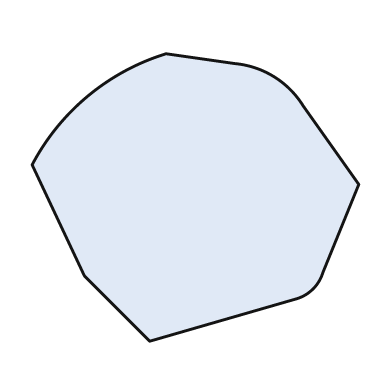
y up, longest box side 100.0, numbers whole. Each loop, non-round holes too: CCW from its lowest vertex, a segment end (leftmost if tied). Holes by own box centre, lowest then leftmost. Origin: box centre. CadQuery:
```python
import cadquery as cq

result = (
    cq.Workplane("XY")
    .moveTo(-14.0, -44.0)
    .lineTo(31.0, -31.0)
    .threePointArc((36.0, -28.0), (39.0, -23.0))
    .lineTo(50.0, 4.0)
    .lineTo(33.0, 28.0)
    .threePointArc((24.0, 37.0), (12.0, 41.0))
    .lineTo(-9.0, 44.0)
    .threePointArc((-33.0, 31.0), (-50.0, 10.0))
    .lineTo(-34.0, -24.0)
    .close()
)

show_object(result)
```